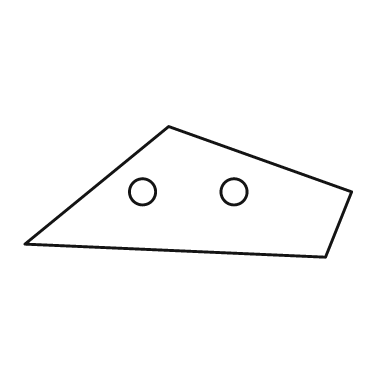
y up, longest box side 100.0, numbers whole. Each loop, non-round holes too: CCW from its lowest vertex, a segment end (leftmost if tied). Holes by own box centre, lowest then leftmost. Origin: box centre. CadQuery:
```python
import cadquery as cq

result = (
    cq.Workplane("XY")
    .moveTo(42.0, -20.0)
    .lineTo(50.0, 0.0)
    .lineTo(-6.0, 20.0)
    .lineTo(-50.0, -16.0)
    .close()
    .moveTo(-14.0, 0.0)
    .circle(4.0)
    .moveTo(14.0, 0.0)
    .circle(4.0)
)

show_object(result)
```